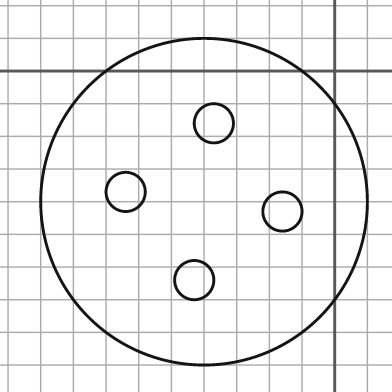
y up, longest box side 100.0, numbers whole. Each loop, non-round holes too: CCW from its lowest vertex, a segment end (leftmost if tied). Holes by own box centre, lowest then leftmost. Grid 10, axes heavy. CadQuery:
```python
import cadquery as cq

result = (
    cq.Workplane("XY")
    .moveTo(-40.0, -40.0)
    .circle(50.0)
    .moveTo(-43.0, -64.0)
    .circle(6.0)
    .moveTo(-16.0, -43.0)
    .circle(6.0)
    .moveTo(-64.0, -37.0)
    .circle(6.0)
    .moveTo(-37.0, -16.0)
    .circle(6.0)
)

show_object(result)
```